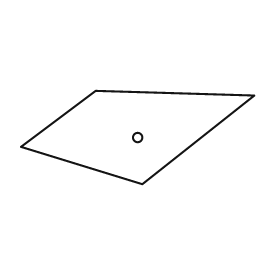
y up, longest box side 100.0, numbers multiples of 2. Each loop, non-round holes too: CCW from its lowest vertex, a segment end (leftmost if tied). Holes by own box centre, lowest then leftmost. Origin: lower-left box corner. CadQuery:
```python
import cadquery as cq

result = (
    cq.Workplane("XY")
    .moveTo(52.0, 0.0)
    .lineTo(100.0, 38.0)
    .lineTo(32.0, 40.0)
    .lineTo(0.0, 16.0)
    .close()
    .moveTo(50.0, 20.0)
    .circle(2.0)
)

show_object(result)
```